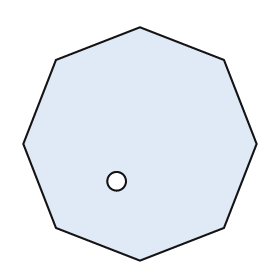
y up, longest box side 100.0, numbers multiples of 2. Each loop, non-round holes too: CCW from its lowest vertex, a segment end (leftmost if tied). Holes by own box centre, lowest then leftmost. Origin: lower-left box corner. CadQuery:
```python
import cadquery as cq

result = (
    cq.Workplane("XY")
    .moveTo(50.0, 0.0)
    .lineTo(86.0, 14.0)
    .lineTo(100.0, 50.0)
    .lineTo(86.0, 86.0)
    .lineTo(50.0, 100.0)
    .lineTo(14.0, 86.0)
    .lineTo(0.0, 50.0)
    .lineTo(14.0, 14.0)
    .close()
    .moveTo(40.0, 34.0)
    .circle(4.0)
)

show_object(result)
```